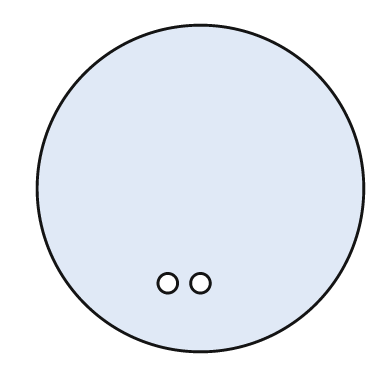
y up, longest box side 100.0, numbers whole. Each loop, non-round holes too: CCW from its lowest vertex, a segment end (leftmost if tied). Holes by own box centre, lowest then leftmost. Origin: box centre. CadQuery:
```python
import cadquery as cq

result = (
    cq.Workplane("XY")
    .moveTo(0.0, 0.0)
    .circle(50.0)
    .moveTo(-10.0, -29.0)
    .circle(3.0)
    .moveTo(0.0, -29.0)
    .circle(3.0)
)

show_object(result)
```